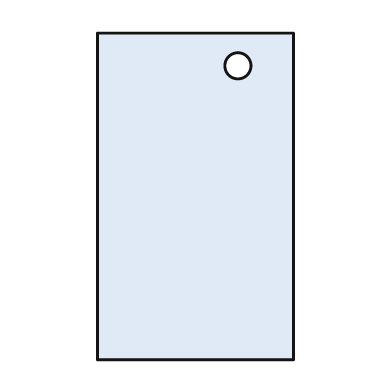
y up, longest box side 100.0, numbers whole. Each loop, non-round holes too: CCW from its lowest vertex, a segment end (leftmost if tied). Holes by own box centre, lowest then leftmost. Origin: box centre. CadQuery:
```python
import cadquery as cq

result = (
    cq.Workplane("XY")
    .moveTo(-30.0, -50.0)
    .lineTo(30.0, -50.0)
    .lineTo(30.0, 50.0)
    .lineTo(-30.0, 50.0)
    .close()
    .moveTo(13.0, 40.0)
    .circle(4.0)
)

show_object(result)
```